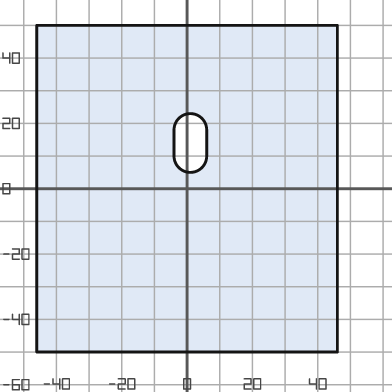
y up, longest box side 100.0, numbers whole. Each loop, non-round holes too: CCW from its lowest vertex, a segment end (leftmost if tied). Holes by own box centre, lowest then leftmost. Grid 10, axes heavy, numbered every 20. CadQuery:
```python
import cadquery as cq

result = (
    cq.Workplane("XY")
    .moveTo(-46.0, -50.0)
    .lineTo(46.0, -50.0)
    .lineTo(46.0, 50.0)
    .lineTo(-46.0, 50.0)
    .close()
    .moveTo(-4.0, 10.0)
    .threePointArc((1.0, 5.0), (6.0, 10.0))
    .lineTo(6.0, 18.0)
    .threePointArc((1.0, 23.0), (-4.0, 18.0))
    .close()
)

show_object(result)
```